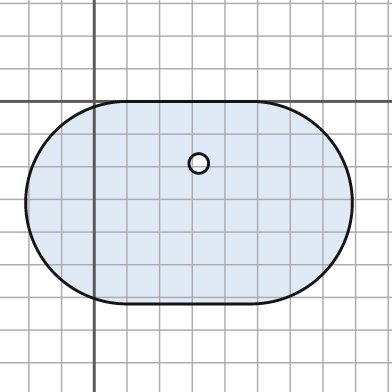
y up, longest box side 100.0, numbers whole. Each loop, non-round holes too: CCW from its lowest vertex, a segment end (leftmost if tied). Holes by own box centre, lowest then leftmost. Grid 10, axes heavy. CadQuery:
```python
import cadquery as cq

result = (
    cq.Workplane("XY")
    .moveTo(10.0, -62.0)
    .lineTo(48.0, -62.0)
    .threePointArc((79.0, -31.0), (48.0, 0.0))
    .lineTo(10.0, 0.0)
    .threePointArc((-21.0, -31.0), (10.0, -62.0))
    .close()
    .moveTo(32.0, -19.0)
    .circle(3.0)
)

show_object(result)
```